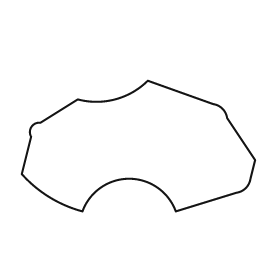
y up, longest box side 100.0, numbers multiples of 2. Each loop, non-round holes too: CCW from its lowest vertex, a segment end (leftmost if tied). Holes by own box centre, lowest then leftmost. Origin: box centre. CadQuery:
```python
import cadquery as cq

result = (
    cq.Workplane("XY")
    .moveTo(-24.0, -28.0)
    .threePointArc((-4.0, -14.0), (16.0, -28.0))
    .lineTo(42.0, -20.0)
    .threePointArc((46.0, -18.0), (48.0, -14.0))
    .lineTo(50.0, -6.0)
    .lineTo(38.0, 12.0)
    .threePointArc((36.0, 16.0), (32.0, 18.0))
    .lineTo(4.0, 28.0)
    .threePointArc((-10.0, 20.0), (-26.0, 20.0))
    .lineTo(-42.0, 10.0)
    .threePointArc((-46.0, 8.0), (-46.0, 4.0))
    .lineTo(-50.0, -12.0)
    .threePointArc((-38.0, -22.0), (-24.0, -28.0))
    .close()
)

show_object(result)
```